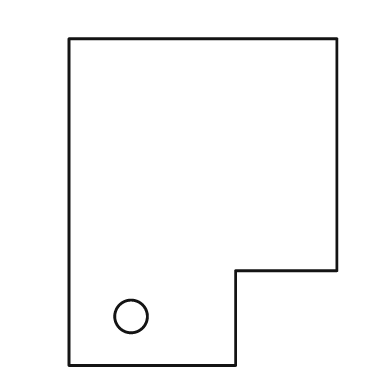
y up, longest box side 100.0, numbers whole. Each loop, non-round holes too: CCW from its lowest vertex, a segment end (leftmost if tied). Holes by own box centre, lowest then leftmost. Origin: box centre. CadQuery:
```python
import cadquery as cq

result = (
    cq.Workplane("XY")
    .moveTo(-41.0, -50.0)
    .lineTo(10.0, -50.0)
    .lineTo(10.0, -21.0)
    .lineTo(41.0, -21.0)
    .lineTo(41.0, 50.0)
    .lineTo(-41.0, 50.0)
    .close()
    .moveTo(-22.0, -35.0)
    .circle(5.0)
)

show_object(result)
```